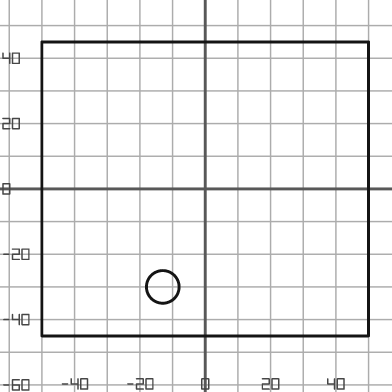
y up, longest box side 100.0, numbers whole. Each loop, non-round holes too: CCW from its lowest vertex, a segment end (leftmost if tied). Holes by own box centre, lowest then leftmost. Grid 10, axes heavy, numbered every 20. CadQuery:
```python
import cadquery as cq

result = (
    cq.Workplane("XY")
    .moveTo(-50.0, -45.0)
    .lineTo(50.0, -45.0)
    .lineTo(50.0, 45.0)
    .lineTo(-50.0, 45.0)
    .close()
    .moveTo(-13.0, -30.0)
    .circle(5.0)
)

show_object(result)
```